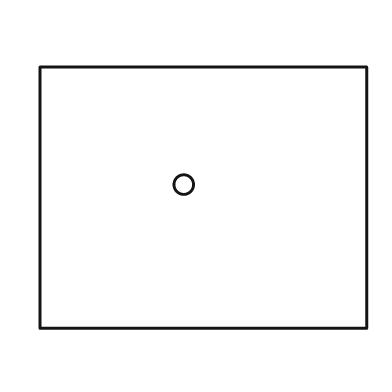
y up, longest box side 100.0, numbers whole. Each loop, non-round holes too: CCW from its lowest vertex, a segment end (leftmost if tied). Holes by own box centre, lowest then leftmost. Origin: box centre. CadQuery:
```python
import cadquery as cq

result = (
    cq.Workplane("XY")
    .moveTo(-50.0, -40.0)
    .lineTo(50.0, -40.0)
    .lineTo(50.0, 40.0)
    .lineTo(-50.0, 40.0)
    .close()
    .moveTo(-6.0, 4.0)
    .circle(3.0)
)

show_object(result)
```